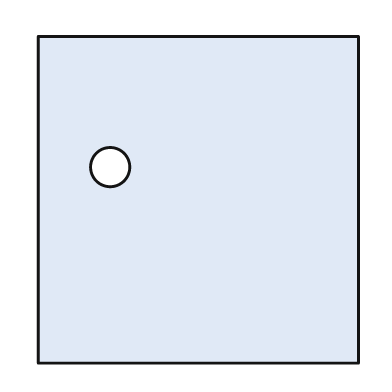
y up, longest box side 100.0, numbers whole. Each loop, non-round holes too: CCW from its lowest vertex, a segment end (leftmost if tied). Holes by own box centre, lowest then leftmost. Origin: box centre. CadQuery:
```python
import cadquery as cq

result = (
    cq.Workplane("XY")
    .moveTo(-49.0, -50.0)
    .lineTo(49.0, -50.0)
    .lineTo(49.0, 50.0)
    .lineTo(-49.0, 50.0)
    .close()
    .moveTo(-27.0, 10.0)
    .circle(6.0)
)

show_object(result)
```